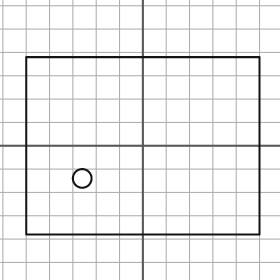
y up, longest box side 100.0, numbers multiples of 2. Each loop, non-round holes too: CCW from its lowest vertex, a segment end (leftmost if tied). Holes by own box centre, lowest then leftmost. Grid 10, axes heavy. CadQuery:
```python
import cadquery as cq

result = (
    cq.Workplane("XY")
    .moveTo(-50.0, -38.0)
    .lineTo(50.0, -38.0)
    .lineTo(50.0, 38.0)
    .lineTo(-50.0, 38.0)
    .close()
    .moveTo(-26.0, -14.0)
    .circle(4.0)
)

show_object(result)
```